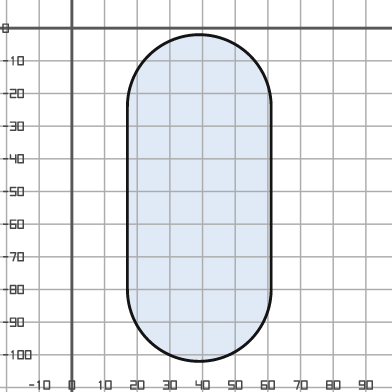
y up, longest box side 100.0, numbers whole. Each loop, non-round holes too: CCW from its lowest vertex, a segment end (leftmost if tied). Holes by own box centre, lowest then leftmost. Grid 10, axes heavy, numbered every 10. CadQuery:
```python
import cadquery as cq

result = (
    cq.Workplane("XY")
    .moveTo(17.0, -80.0)
    .threePointArc((39.0, -102.0), (61.0, -80.0))
    .lineTo(61.0, -24.0)
    .threePointArc((39.0, -2.0), (17.0, -24.0))
    .close()
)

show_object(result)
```